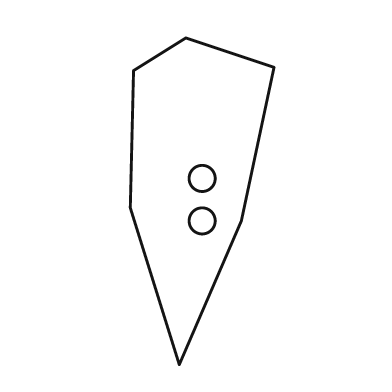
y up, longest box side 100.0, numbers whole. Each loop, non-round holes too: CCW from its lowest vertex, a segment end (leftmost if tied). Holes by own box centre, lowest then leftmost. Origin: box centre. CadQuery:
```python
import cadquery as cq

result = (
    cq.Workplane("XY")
    .moveTo(-7.0, -50.0)
    .lineTo(12.0, -6.0)
    .lineTo(22.0, 41.0)
    .lineTo(-5.0, 50.0)
    .lineTo(-21.0, 40.0)
    .lineTo(-22.0, -2.0)
    .close()
    .moveTo(0.0, -6.0)
    .circle(4.0)
    .moveTo(0.0, 7.0)
    .circle(4.0)
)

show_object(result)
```